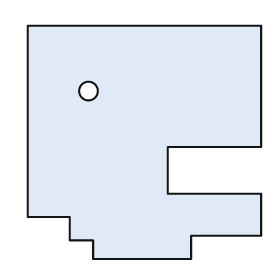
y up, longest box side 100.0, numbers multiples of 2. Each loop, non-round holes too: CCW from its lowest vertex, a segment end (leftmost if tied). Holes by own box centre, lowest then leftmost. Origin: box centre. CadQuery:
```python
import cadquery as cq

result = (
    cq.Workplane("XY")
    .moveTo(-22.0, -50.0)
    .lineTo(20.0, -50.0)
    .lineTo(20.0, -40.0)
    .lineTo(50.0, -40.0)
    .lineTo(50.0, -22.0)
    .lineTo(10.0, -22.0)
    .lineTo(10.0, -2.0)
    .lineTo(50.0, -2.0)
    .lineTo(50.0, 50.0)
    .lineTo(-50.0, 50.0)
    .lineTo(-50.0, -32.0)
    .lineTo(-32.0, -32.0)
    .lineTo(-32.0, -42.0)
    .lineTo(-22.0, -42.0)
    .close()
    .moveTo(-24.0, 22.0)
    .circle(4.0)
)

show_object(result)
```